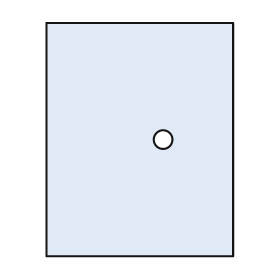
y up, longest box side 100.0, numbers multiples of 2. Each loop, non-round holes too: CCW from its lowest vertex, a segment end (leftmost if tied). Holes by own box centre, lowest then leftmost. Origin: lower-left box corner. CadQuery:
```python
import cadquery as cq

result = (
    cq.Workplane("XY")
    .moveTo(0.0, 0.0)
    .lineTo(80.0, 0.0)
    .lineTo(80.0, 100.0)
    .lineTo(0.0, 100.0)
    .close()
    .moveTo(50.0, 50.0)
    .circle(4.0)
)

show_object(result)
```